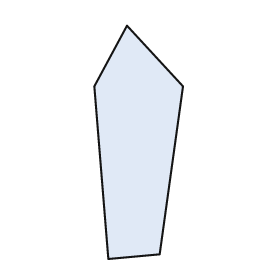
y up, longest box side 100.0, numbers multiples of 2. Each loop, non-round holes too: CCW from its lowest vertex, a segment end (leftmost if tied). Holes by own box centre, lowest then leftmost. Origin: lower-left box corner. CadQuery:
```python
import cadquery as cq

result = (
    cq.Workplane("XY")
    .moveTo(6.0, 0.0)
    .lineTo(28.0, 2.0)
    .lineTo(38.0, 74.0)
    .lineTo(14.0, 100.0)
    .lineTo(0.0, 74.0)
    .close()
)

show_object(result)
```